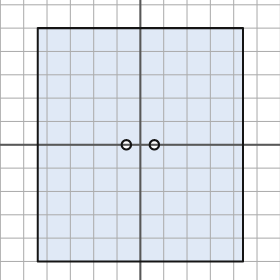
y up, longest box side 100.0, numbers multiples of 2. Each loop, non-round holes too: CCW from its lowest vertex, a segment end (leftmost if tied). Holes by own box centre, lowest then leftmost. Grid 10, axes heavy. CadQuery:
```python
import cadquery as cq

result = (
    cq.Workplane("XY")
    .moveTo(-44.0, -50.0)
    .lineTo(44.0, -50.0)
    .lineTo(44.0, 50.0)
    .lineTo(-44.0, 50.0)
    .close()
    .moveTo(-6.0, 0.0)
    .circle(2.0)
    .moveTo(6.0, 0.0)
    .circle(2.0)
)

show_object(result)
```